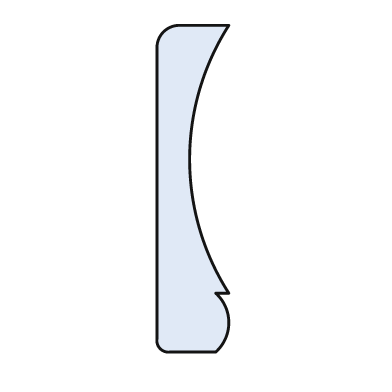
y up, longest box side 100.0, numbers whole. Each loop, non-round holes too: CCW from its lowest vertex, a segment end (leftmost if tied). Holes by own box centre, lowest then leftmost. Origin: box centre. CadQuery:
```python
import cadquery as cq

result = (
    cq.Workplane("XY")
    .moveTo(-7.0, -50.0)
    .lineTo(7.0, -50.0)
    .threePointArc((11.0, -41.0), (7.0, -32.0))
    .lineTo(11.0, -32.0)
    .threePointArc((-1.0, 9.0), (11.0, 50.0))
    .lineTo(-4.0, 50.0)
    .threePointArc((-9.0, 48.0), (-11.0, 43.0))
    .lineTo(-11.0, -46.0)
    .threePointArc((-10.0, -49.0), (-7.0, -50.0))
    .close()
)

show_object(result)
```